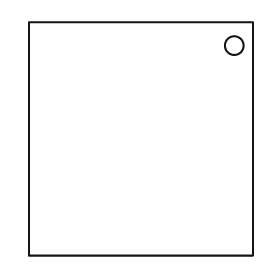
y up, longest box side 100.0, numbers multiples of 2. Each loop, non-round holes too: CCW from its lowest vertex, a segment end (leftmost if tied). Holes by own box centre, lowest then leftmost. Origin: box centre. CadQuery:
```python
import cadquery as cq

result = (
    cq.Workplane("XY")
    .moveTo(-48.0, -50.0)
    .lineTo(48.0, -50.0)
    .lineTo(48.0, 50.0)
    .lineTo(-48.0, 50.0)
    .close()
    .moveTo(40.0, 40.0)
    .circle(4.0)
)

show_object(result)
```